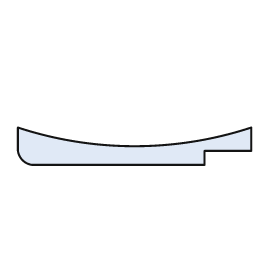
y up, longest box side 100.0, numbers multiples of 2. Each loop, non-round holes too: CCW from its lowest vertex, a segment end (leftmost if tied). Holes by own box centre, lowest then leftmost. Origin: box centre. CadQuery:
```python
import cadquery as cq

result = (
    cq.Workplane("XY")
    .moveTo(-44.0, -8.0)
    .lineTo(30.0, -8.0)
    .lineTo(30.0, -2.0)
    .lineTo(50.0, -2.0)
    .lineTo(50.0, 8.0)
    .threePointArc((0.0, 0.0), (-50.0, 8.0))
    .lineTo(-50.0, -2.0)
    .threePointArc((-48.0, -6.0), (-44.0, -8.0))
    .close()
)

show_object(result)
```